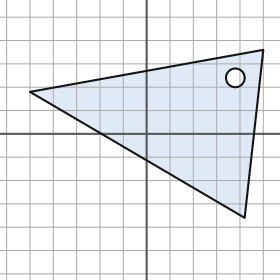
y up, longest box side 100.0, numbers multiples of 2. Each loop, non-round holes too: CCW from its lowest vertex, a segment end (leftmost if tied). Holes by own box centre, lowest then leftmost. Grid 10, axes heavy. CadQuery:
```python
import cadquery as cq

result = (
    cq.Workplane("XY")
    .moveTo(42.0, -36.0)
    .lineTo(50.0, 36.0)
    .lineTo(-50.0, 18.0)
    .close()
    .moveTo(38.0, 24.0)
    .circle(4.0)
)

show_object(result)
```